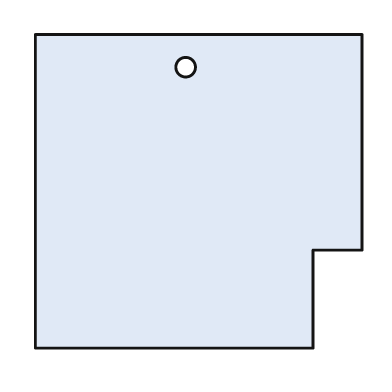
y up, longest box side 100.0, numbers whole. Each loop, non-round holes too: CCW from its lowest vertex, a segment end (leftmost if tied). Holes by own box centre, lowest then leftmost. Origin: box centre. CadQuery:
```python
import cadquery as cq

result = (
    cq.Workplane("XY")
    .moveTo(-50.0, -48.0)
    .lineTo(35.0, -48.0)
    .lineTo(35.0, -18.0)
    .lineTo(50.0, -18.0)
    .lineTo(50.0, 48.0)
    .lineTo(-50.0, 48.0)
    .close()
    .moveTo(-4.0, 38.0)
    .circle(3.0)
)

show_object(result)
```